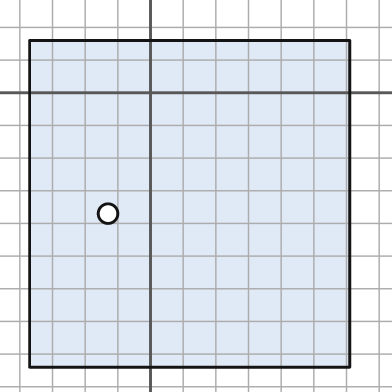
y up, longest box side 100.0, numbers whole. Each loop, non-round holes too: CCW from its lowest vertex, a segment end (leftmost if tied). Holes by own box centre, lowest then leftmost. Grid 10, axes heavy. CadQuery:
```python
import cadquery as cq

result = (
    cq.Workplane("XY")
    .moveTo(-37.0, -84.0)
    .lineTo(61.0, -84.0)
    .lineTo(61.0, 16.0)
    .lineTo(-37.0, 16.0)
    .close()
    .moveTo(-13.0, -37.0)
    .circle(3.0)
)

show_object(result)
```